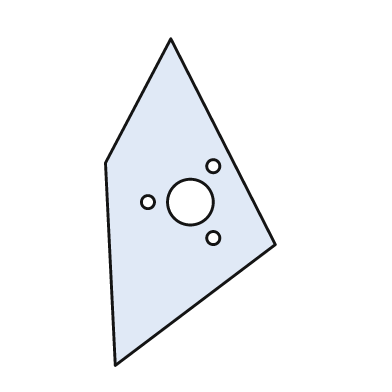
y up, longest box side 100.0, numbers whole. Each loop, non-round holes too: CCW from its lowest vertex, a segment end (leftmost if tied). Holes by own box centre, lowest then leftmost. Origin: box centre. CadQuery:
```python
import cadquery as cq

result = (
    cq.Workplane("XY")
    .moveTo(-23.0, -50.0)
    .lineTo(26.0, -13.0)
    .lineTo(-6.0, 50.0)
    .lineTo(-26.0, 12.0)
    .close()
    .moveTo(7.0, -11.0)
    .circle(2.0)
    .moveTo(-13.0, 0.0)
    .circle(2.0)
    .moveTo(0.0, 0.0)
    .circle(7.0)
    .moveTo(7.0, 11.0)
    .circle(2.0)
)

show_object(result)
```